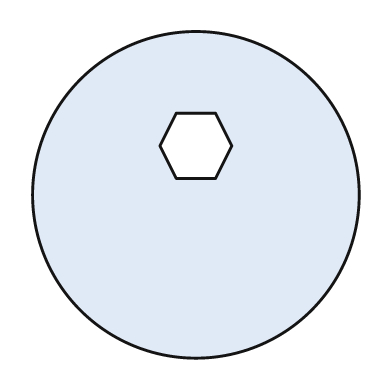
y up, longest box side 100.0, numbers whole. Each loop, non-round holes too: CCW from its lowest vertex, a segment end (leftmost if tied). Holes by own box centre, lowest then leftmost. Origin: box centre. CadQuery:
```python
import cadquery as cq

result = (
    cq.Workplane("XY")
    .moveTo(0.0, 0.0)
    .circle(50.0)
    .moveTo(-6.0, 5.0)
    .lineTo(6.0, 5.0)
    .lineTo(11.0, 15.0)
    .lineTo(6.0, 25.0)
    .lineTo(-6.0, 25.0)
    .lineTo(-11.0, 15.0)
    .close()
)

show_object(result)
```